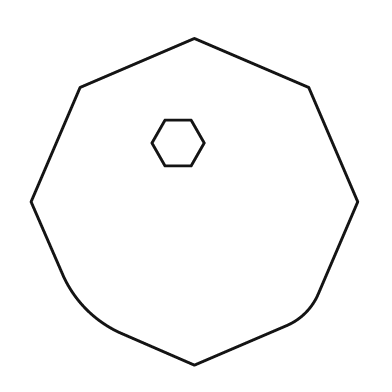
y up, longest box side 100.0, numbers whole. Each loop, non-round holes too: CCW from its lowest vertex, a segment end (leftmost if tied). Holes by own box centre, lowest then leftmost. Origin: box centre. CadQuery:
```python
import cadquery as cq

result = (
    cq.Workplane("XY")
    .moveTo(0.0, -50.0)
    .lineTo(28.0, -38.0)
    .threePointArc((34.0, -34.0), (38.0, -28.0))
    .lineTo(50.0, 0.0)
    .lineTo(35.0, 35.0)
    .lineTo(0.0, 50.0)
    .lineTo(-35.0, 35.0)
    .lineTo(-50.0, 0.0)
    .lineTo(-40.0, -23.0)
    .threePointArc((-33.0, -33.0), (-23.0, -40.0))
    .close()
    .moveTo(-9.0, 11.0)
    .lineTo(-1.0, 11.0)
    .lineTo(3.0, 18.0)
    .lineTo(-1.0, 25.0)
    .lineTo(-9.0, 25.0)
    .lineTo(-13.0, 18.0)
    .close()
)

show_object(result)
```